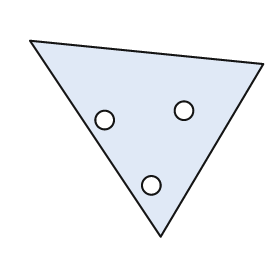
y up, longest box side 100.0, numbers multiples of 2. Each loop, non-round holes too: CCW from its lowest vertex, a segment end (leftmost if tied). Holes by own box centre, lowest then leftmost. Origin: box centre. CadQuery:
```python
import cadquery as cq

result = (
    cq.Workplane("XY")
    .moveTo(6.0, -42.0)
    .lineTo(50.0, 32.0)
    .lineTo(-50.0, 42.0)
    .close()
    .moveTo(2.0, -20.0)
    .circle(4.0)
    .moveTo(-18.0, 8.0)
    .circle(4.0)
    .moveTo(16.0, 12.0)
    .circle(4.0)
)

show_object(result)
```